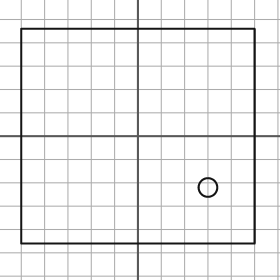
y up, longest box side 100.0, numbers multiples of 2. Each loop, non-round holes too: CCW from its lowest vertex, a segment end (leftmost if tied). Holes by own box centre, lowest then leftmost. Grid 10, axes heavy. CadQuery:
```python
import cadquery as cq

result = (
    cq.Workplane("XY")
    .moveTo(-50.0, -46.0)
    .lineTo(50.0, -46.0)
    .lineTo(50.0, 46.0)
    .lineTo(-50.0, 46.0)
    .close()
    .moveTo(30.0, -22.0)
    .circle(4.0)
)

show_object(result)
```